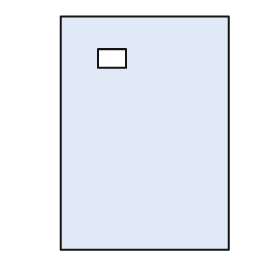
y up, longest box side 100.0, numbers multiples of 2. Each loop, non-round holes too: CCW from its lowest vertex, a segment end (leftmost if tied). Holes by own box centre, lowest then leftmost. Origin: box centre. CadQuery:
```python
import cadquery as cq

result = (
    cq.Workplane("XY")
    .moveTo(-36.0, -50.0)
    .lineTo(36.0, -50.0)
    .lineTo(36.0, 50.0)
    .lineTo(-36.0, 50.0)
    .close()
    .moveTo(-20.0, 28.0)
    .lineTo(-8.0, 28.0)
    .lineTo(-8.0, 36.0)
    .lineTo(-20.0, 36.0)
    .close()
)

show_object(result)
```